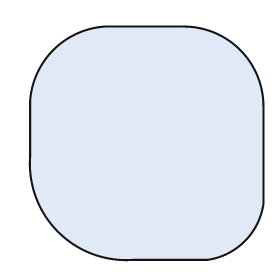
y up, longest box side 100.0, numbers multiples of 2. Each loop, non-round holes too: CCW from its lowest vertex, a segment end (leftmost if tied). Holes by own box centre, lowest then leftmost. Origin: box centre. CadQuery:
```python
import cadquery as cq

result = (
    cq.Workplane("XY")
    .moveTo(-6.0, -50.0)
    .lineTo(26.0, -50.0)
    .threePointArc((42.0, -42.0), (50.0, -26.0))
    .lineTo(50.0, 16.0)
    .threePointArc((40.0, 40.0), (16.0, 50.0))
    .lineTo(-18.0, 50.0)
    .threePointArc((-40.0, 40.0), (-50.0, 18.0))
    .lineTo(-50.0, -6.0)
    .threePointArc((-38.0, -38.0), (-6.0, -50.0))
    .close()
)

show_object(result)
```